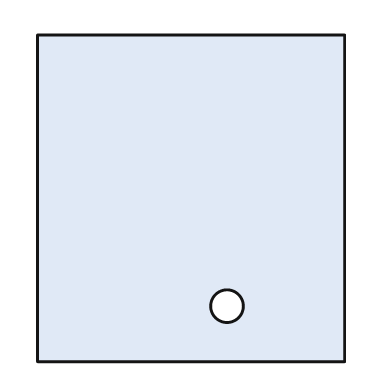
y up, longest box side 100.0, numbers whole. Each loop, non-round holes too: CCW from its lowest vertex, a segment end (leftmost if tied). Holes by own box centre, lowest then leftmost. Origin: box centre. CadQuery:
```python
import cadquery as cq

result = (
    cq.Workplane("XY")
    .moveTo(-47.0, -50.0)
    .lineTo(47.0, -50.0)
    .lineTo(47.0, 50.0)
    .lineTo(-47.0, 50.0)
    .close()
    .moveTo(11.0, -33.0)
    .circle(5.0)
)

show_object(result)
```